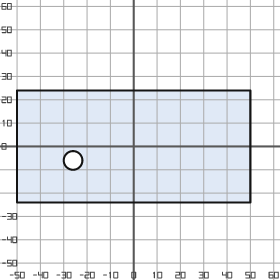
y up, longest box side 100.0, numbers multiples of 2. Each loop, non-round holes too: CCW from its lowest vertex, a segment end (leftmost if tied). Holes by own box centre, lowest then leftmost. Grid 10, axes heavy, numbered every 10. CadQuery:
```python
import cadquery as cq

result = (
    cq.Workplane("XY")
    .moveTo(-50.0, -24.0)
    .lineTo(50.0, -24.0)
    .lineTo(50.0, 24.0)
    .lineTo(-50.0, 24.0)
    .close()
    .moveTo(-26.0, -6.0)
    .circle(4.0)
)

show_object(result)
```